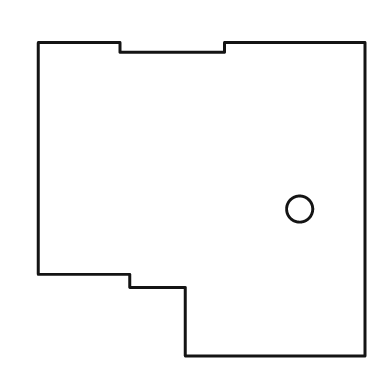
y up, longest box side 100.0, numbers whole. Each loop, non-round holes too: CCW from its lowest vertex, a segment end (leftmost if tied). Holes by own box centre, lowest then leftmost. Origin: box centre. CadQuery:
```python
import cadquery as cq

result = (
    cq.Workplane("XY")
    .moveTo(-5.0, -48.0)
    .lineTo(50.0, -48.0)
    .lineTo(50.0, 48.0)
    .lineTo(7.0, 48.0)
    .lineTo(7.0, 45.0)
    .lineTo(-25.0, 45.0)
    .lineTo(-25.0, 48.0)
    .lineTo(-50.0, 48.0)
    .lineTo(-50.0, -23.0)
    .lineTo(-22.0, -23.0)
    .lineTo(-22.0, -27.0)
    .lineTo(-5.0, -27.0)
    .close()
    .moveTo(30.0, -3.0)
    .circle(4.0)
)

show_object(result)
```